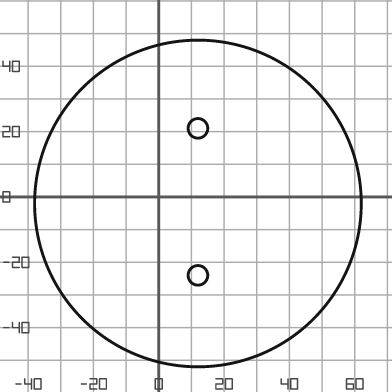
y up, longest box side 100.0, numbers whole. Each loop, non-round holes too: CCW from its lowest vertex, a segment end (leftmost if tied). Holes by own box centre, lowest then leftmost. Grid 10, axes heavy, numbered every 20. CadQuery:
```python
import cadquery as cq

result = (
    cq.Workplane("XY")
    .moveTo(12.0, -2.0)
    .circle(50.0)
    .moveTo(12.0, -24.0)
    .circle(3.0)
    .moveTo(12.0, 21.0)
    .circle(3.0)
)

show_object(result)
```